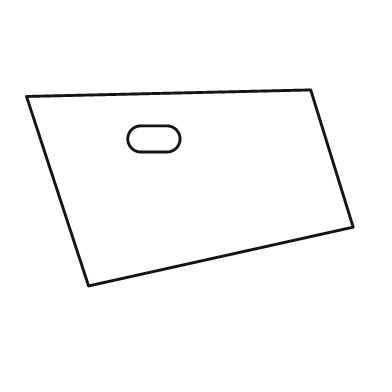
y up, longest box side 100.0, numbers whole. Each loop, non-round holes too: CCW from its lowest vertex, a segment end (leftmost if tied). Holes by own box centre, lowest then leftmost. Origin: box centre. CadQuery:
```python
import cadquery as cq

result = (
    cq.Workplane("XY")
    .moveTo(-31.0, -30.0)
    .lineTo(50.0, -12.0)
    .lineTo(37.0, 30.0)
    .lineTo(-50.0, 28.0)
    .close()
    .moveTo(-15.0, 11.0)
    .lineTo(-7.0, 11.0)
    .threePointArc((-3.0, 15.0), (-7.0, 19.0))
    .lineTo(-15.0, 19.0)
    .threePointArc((-19.0, 15.0), (-15.0, 11.0))
    .close()
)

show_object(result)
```